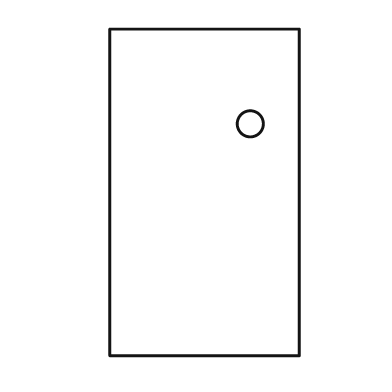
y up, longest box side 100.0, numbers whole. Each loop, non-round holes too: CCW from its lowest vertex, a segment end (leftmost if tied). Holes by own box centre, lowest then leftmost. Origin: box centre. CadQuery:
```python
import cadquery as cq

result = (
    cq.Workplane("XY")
    .moveTo(-29.0, -50.0)
    .lineTo(29.0, -50.0)
    .lineTo(29.0, 50.0)
    .lineTo(-29.0, 50.0)
    .close()
    .moveTo(14.0, 21.0)
    .circle(4.0)
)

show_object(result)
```